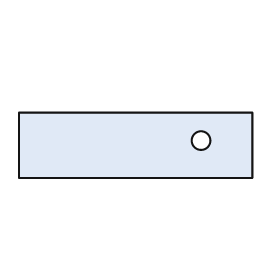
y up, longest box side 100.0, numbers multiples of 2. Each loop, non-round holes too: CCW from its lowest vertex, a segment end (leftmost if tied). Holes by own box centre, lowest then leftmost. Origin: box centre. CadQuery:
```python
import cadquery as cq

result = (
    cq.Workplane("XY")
    .moveTo(-50.0, -14.0)
    .lineTo(50.0, -14.0)
    .lineTo(50.0, 14.0)
    .lineTo(-50.0, 14.0)
    .close()
    .moveTo(28.0, 2.0)
    .circle(4.0)
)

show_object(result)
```